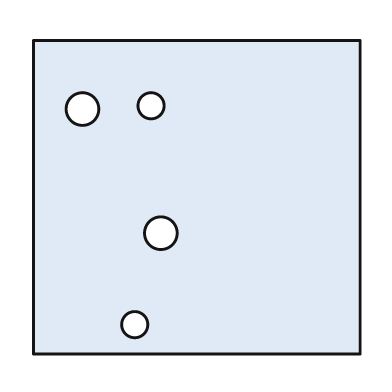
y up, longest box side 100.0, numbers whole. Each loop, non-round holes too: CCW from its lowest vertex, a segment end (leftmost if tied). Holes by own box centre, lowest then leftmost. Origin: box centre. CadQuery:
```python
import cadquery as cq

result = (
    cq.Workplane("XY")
    .moveTo(-50.0, -48.0)
    .lineTo(50.0, -48.0)
    .lineTo(50.0, 48.0)
    .lineTo(-50.0, 48.0)
    .close()
    .moveTo(-19.0, -39.0)
    .circle(4.0)
    .moveTo(-11.0, -11.0)
    .circle(5.0)
    .moveTo(-35.0, 27.0)
    .circle(5.0)
    .moveTo(-14.0, 28.0)
    .circle(4.0)
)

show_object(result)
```